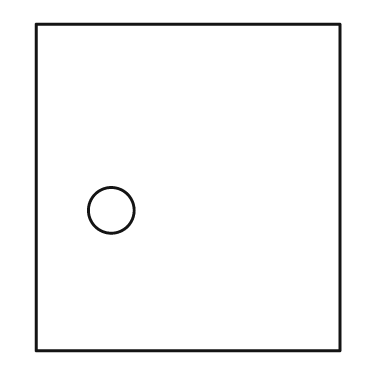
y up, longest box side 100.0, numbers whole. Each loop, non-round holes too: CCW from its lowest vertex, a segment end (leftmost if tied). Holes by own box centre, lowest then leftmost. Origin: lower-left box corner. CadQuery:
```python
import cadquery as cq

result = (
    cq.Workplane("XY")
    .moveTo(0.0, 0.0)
    .lineTo(93.0, 0.0)
    .lineTo(93.0, 100.0)
    .lineTo(0.0, 100.0)
    .close()
    .moveTo(23.0, 43.0)
    .circle(7.0)
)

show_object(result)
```